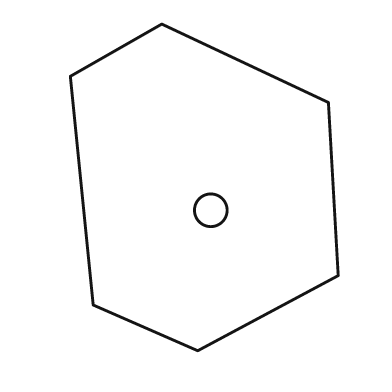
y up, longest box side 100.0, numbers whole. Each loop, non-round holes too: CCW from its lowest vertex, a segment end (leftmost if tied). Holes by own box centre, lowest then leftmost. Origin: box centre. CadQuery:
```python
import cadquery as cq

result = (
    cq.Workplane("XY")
    .moveTo(-2.0, -50.0)
    .lineTo(41.0, -27.0)
    .lineTo(38.0, 26.0)
    .lineTo(-13.0, 50.0)
    .lineTo(-41.0, 34.0)
    .lineTo(-34.0, -36.0)
    .close()
    .moveTo(2.0, -7.0)
    .circle(5.0)
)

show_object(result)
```